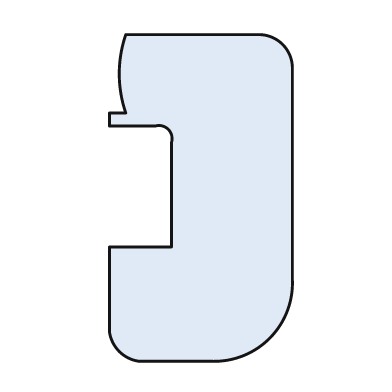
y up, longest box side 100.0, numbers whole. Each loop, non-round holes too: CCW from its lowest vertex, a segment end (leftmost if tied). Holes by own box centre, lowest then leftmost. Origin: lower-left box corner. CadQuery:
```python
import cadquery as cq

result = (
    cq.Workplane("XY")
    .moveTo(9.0, 0.0)
    .lineTo(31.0, 0.0)
    .threePointArc((49.0, 7.0), (56.0, 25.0))
    .lineTo(56.0, 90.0)
    .threePointArc((53.0, 97.0), (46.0, 100.0))
    .lineTo(5.0, 100.0)
    .threePointArc((3.0, 88.0), (5.0, 76.0))
    .lineTo(0.0, 76.0)
    .lineTo(0.0, 72.0)
    .lineTo(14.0, 72.0)
    .threePointArc((18.0, 71.0), (19.0, 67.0))
    .lineTo(19.0, 35.0)
    .lineTo(0.0, 35.0)
    .lineTo(0.0, 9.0)
    .threePointArc((3.0, 3.0), (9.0, 0.0))
    .close()
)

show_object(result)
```